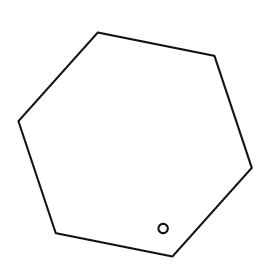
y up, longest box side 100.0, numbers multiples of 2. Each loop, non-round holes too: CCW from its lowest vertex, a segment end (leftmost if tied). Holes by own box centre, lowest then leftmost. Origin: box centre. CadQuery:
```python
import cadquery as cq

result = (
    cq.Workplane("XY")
    .moveTo(16.0, -48.0)
    .lineTo(50.0, -10.0)
    .lineTo(34.0, 38.0)
    .lineTo(-16.0, 48.0)
    .lineTo(-50.0, 10.0)
    .lineTo(-34.0, -38.0)
    .close()
    .moveTo(12.0, -36.0)
    .circle(2.0)
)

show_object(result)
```